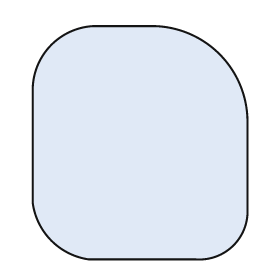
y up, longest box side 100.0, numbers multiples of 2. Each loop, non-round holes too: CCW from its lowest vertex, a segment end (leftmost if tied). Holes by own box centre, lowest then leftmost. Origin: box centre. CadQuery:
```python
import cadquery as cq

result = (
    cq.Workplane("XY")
    .moveTo(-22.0, -50.0)
    .lineTo(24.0, -50.0)
    .threePointArc((40.0, -44.0), (46.0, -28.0))
    .lineTo(46.0, 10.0)
    .threePointArc((34.0, 38.0), (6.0, 50.0))
    .lineTo(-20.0, 50.0)
    .threePointArc((-38.0, 42.0), (-46.0, 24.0))
    .lineTo(-46.0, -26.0)
    .threePointArc((-38.0, -42.0), (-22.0, -50.0))
    .close()
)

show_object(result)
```